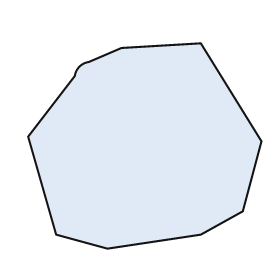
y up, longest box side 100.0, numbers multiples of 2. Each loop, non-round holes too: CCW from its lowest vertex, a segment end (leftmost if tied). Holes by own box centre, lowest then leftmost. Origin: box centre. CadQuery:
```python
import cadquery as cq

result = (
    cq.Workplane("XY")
    .moveTo(-16.0, -44.0)
    .lineTo(24.0, -38.0)
    .lineTo(42.0, -28.0)
    .lineTo(50.0, 2.0)
    .lineTo(24.0, 44.0)
    .lineTo(-10.0, 42.0)
    .lineTo(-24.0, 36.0)
    .threePointArc((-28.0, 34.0), (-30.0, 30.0))
    .lineTo(-50.0, 4.0)
    .lineTo(-38.0, -38.0)
    .close()
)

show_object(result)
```